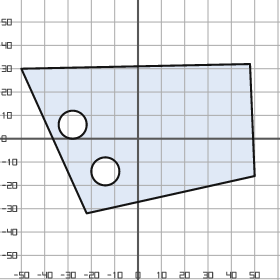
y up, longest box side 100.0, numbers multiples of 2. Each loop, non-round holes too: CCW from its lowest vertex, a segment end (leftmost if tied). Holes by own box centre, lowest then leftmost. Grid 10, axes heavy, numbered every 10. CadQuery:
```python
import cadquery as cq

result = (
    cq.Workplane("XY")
    .moveTo(-22.0, -32.0)
    .lineTo(50.0, -16.0)
    .lineTo(48.0, 32.0)
    .lineTo(-50.0, 30.0)
    .close()
    .moveTo(-14.0, -14.0)
    .circle(6.0)
    .moveTo(-28.0, 6.0)
    .circle(6.0)
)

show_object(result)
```